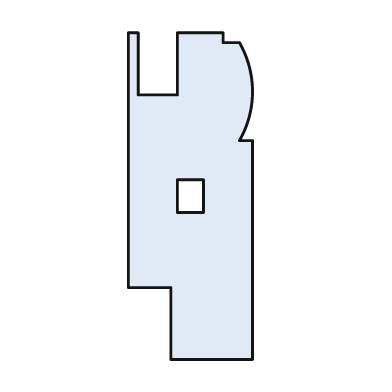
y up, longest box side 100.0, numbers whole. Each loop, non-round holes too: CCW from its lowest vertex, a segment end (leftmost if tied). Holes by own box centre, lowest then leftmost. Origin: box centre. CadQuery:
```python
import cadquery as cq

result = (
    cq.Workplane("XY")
    .moveTo(-6.0, -50.0)
    .lineTo(19.0, -50.0)
    .lineTo(19.0, 17.0)
    .lineTo(15.0, 17.0)
    .threePointArc((19.0, 32.0), (15.0, 47.0))
    .lineTo(10.0, 47.0)
    .lineTo(10.0, 50.0)
    .lineTo(-4.0, 50.0)
    .lineTo(-4.0, 31.0)
    .lineTo(-16.0, 31.0)
    .lineTo(-16.0, 50.0)
    .lineTo(-19.0, 50.0)
    .lineTo(-19.0, -28.0)
    .lineTo(-6.0, -28.0)
    .close()
    .moveTo(-4.0, -5.0)
    .lineTo(4.0, -5.0)
    .lineTo(4.0, 5.0)
    .lineTo(-4.0, 5.0)
    .close()
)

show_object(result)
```